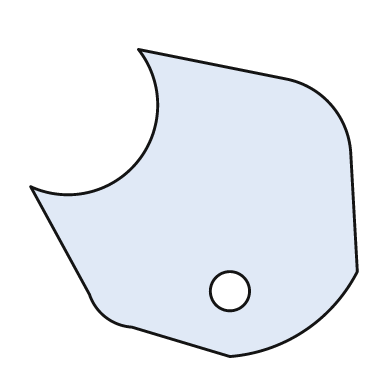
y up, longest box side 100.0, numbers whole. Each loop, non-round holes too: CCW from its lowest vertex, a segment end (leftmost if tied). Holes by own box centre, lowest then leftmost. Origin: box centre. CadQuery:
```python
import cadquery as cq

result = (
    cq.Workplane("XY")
    .moveTo(11.0, -47.0)
    .threePointArc((34.0, -39.0), (50.0, -21.0))
    .lineTo(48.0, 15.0)
    .threePointArc((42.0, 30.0), (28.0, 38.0))
    .lineTo(-17.0, 47.0)
    .threePointArc((-17.0, 13.0), (-50.0, 5.0))
    .lineTo(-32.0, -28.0)
    .threePointArc((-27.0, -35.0), (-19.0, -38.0))
    .close()
    .moveTo(11.0, -27.0)
    .circle(6.0)
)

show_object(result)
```